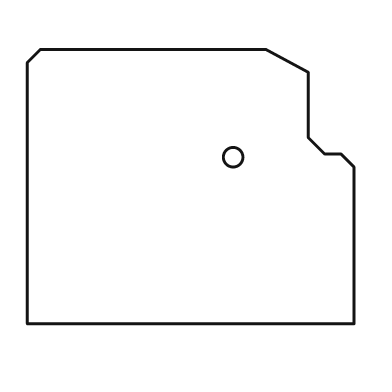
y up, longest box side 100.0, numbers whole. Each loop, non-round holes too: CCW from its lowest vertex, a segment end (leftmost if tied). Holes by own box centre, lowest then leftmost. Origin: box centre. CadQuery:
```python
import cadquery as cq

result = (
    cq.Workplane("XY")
    .moveTo(-50.0, -42.0)
    .lineTo(50.0, -42.0)
    .lineTo(50.0, 6.0)
    .lineTo(46.0, 10.0)
    .lineTo(41.0, 10.0)
    .lineTo(36.0, 15.0)
    .lineTo(36.0, 35.0)
    .lineTo(23.0, 42.0)
    .lineTo(-46.0, 42.0)
    .lineTo(-50.0, 38.0)
    .close()
    .moveTo(13.0, 9.0)
    .circle(3.0)
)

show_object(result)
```